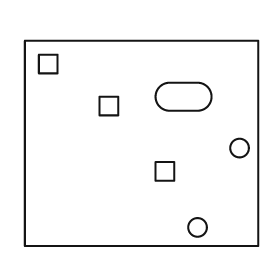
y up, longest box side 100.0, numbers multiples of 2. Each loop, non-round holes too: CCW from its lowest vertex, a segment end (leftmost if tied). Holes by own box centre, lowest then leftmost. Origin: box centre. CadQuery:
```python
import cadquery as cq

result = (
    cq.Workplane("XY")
    .moveTo(-50.0, -44.0)
    .lineTo(50.0, -44.0)
    .lineTo(50.0, 44.0)
    .lineTo(-50.0, 44.0)
    .close()
    .moveTo(24.0, -36.0)
    .circle(4.0)
    .moveTo(6.0, -16.0)
    .lineTo(14.0, -16.0)
    .lineTo(14.0, -8.0)
    .lineTo(6.0, -8.0)
    .close()
    .moveTo(42.0, -2.0)
    .circle(4.0)
    .moveTo(-18.0, 12.0)
    .lineTo(-10.0, 12.0)
    .lineTo(-10.0, 20.0)
    .lineTo(-18.0, 20.0)
    .close()
    .moveTo(12.0, 14.0)
    .lineTo(24.0, 14.0)
    .threePointArc((30.0, 20.0), (24.0, 26.0))
    .lineTo(12.0, 26.0)
    .threePointArc((6.0, 20.0), (12.0, 14.0))
    .close()
    .moveTo(-44.0, 30.0)
    .lineTo(-36.0, 30.0)
    .lineTo(-36.0, 38.0)
    .lineTo(-44.0, 38.0)
    .close()
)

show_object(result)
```